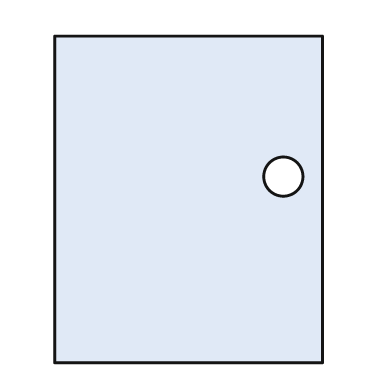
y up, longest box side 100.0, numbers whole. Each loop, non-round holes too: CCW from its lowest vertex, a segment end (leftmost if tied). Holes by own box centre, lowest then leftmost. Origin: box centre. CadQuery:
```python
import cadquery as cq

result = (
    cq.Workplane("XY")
    .moveTo(-41.0, -50.0)
    .lineTo(41.0, -50.0)
    .lineTo(41.0, 50.0)
    .lineTo(-41.0, 50.0)
    .close()
    .moveTo(29.0, 7.0)
    .circle(6.0)
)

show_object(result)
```